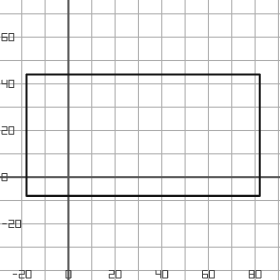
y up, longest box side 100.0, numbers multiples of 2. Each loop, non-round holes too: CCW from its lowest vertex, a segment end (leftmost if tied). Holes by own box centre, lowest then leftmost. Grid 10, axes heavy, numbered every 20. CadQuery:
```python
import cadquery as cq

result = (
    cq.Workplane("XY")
    .moveTo(-18.0, -8.0)
    .lineTo(82.0, -8.0)
    .lineTo(82.0, 44.0)
    .lineTo(-18.0, 44.0)
    .close()
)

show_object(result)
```